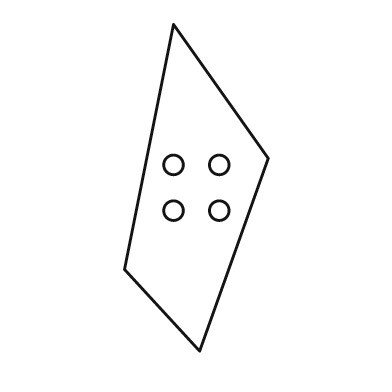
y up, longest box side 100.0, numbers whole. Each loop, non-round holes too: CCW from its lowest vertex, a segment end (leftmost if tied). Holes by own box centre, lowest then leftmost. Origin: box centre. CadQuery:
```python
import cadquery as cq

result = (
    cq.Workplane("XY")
    .moveTo(1.0, -50.0)
    .lineTo(22.0, 9.0)
    .lineTo(-7.0, 50.0)
    .lineTo(-22.0, -25.0)
    .close()
    .moveTo(-7.0, -7.0)
    .circle(3.0)
    .moveTo(7.0, -7.0)
    .circle(3.0)
    .moveTo(-7.0, 7.0)
    .circle(3.0)
    .moveTo(7.0, 7.0)
    .circle(3.0)
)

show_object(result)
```